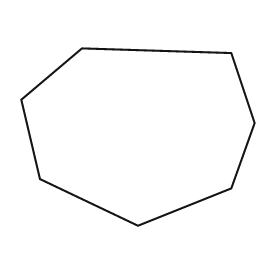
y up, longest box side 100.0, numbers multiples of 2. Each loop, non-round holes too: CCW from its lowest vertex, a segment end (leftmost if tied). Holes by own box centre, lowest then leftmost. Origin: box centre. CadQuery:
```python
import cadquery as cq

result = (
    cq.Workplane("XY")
    .moveTo(0.0, -38.0)
    .lineTo(40.0, -22.0)
    .lineTo(50.0, 6.0)
    .lineTo(40.0, 36.0)
    .lineTo(-24.0, 38.0)
    .lineTo(-50.0, 16.0)
    .lineTo(-42.0, -18.0)
    .close()
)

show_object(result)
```